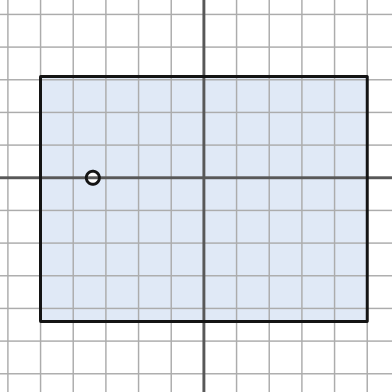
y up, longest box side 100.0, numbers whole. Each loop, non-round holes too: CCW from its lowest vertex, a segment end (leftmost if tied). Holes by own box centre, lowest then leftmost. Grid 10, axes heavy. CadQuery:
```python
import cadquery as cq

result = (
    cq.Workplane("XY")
    .moveTo(-50.0, -44.0)
    .lineTo(50.0, -44.0)
    .lineTo(50.0, 31.0)
    .lineTo(-50.0, 31.0)
    .close()
    .moveTo(-34.0, 0.0)
    .circle(2.0)
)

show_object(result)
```